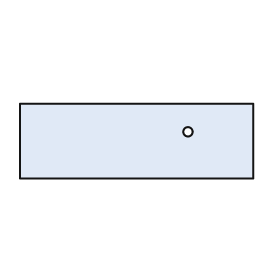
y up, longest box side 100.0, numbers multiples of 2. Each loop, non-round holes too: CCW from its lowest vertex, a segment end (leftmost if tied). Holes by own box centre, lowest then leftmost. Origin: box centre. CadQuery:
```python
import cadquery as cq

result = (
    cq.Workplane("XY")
    .moveTo(-50.0, -16.0)
    .lineTo(50.0, -16.0)
    .lineTo(50.0, 16.0)
    .lineTo(-50.0, 16.0)
    .close()
    .moveTo(22.0, 4.0)
    .circle(2.0)
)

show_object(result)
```